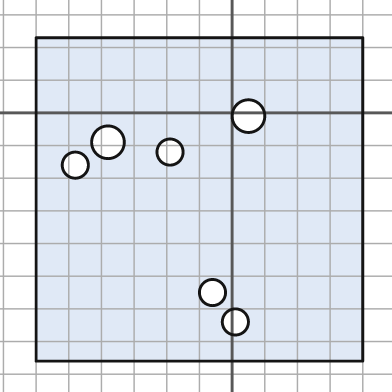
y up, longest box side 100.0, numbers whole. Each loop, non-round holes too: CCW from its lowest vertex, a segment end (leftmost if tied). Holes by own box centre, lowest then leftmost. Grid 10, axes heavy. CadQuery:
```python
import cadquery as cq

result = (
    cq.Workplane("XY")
    .moveTo(-60.0, -76.0)
    .lineTo(40.0, -76.0)
    .lineTo(40.0, 23.0)
    .lineTo(-60.0, 23.0)
    .close()
    .moveTo(1.0, -64.0)
    .circle(4.0)
    .moveTo(-6.0, -55.0)
    .circle(4.0)
    .moveTo(-48.0, -16.0)
    .circle(4.0)
    .moveTo(-19.0, -12.0)
    .circle(4.0)
    .moveTo(-38.0, -9.0)
    .circle(5.0)
    .moveTo(5.0, -1.0)
    .circle(5.0)
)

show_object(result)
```